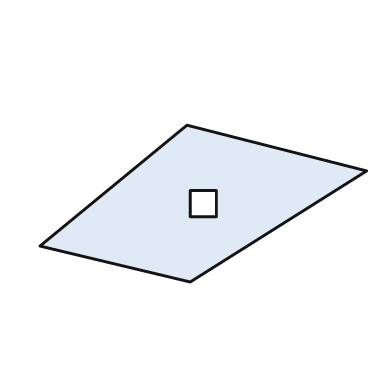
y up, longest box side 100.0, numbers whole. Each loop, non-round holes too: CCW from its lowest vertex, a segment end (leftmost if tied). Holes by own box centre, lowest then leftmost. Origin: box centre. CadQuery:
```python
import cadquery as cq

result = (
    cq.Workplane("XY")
    .moveTo(-4.0, -24.0)
    .lineTo(50.0, 10.0)
    .lineTo(-5.0, 24.0)
    .lineTo(-50.0, -13.0)
    .close()
    .moveTo(-4.0, -4.0)
    .lineTo(4.0, -4.0)
    .lineTo(4.0, 4.0)
    .lineTo(-4.0, 4.0)
    .close()
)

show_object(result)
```